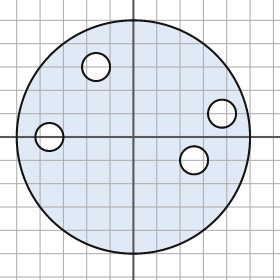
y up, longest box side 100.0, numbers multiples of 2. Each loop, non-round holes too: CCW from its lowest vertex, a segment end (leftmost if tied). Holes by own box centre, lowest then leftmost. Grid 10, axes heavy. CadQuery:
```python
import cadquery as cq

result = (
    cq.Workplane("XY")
    .moveTo(0.0, 0.0)
    .circle(50.0)
    .moveTo(26.0, -10.0)
    .circle(6.0)
    .moveTo(-36.0, 0.0)
    .circle(6.0)
    .moveTo(38.0, 10.0)
    .circle(6.0)
    .moveTo(-16.0, 30.0)
    .circle(6.0)
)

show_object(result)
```